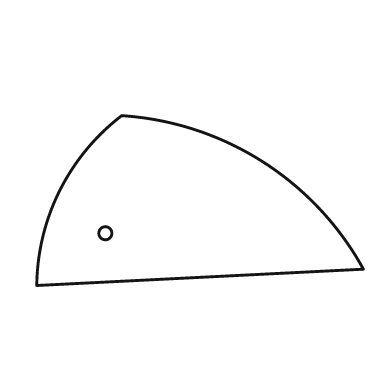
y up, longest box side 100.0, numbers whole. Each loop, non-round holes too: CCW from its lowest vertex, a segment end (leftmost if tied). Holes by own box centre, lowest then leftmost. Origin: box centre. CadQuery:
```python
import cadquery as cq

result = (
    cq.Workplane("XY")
    .moveTo(-50.0, -26.0)
    .lineTo(50.0, -21.0)
    .threePointArc((19.0, 12.0), (-24.0, 26.0))
    .threePointArc((-43.0, 3.0), (-50.0, -26.0))
    .close()
    .moveTo(-29.0, -10.0)
    .circle(2.0)
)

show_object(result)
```